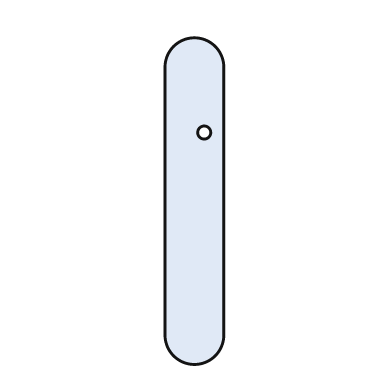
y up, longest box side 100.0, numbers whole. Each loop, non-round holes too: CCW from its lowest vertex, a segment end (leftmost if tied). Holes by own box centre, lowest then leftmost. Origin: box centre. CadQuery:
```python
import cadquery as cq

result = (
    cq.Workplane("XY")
    .moveTo(-9.0, -41.0)
    .threePointArc((0.0, -50.0), (9.0, -41.0))
    .lineTo(9.0, 41.0)
    .threePointArc((0.0, 50.0), (-9.0, 41.0))
    .close()
    .moveTo(3.0, 21.0)
    .circle(2.0)
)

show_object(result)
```